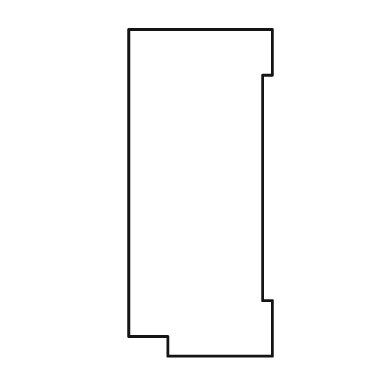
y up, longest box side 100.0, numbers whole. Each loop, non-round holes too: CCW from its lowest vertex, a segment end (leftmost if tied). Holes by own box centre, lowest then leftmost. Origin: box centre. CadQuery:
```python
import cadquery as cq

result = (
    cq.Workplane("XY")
    .moveTo(-10.0, -50.0)
    .lineTo(22.0, -50.0)
    .lineTo(22.0, -33.0)
    .lineTo(19.0, -33.0)
    .lineTo(19.0, 36.0)
    .lineTo(22.0, 36.0)
    .lineTo(22.0, 50.0)
    .lineTo(-22.0, 50.0)
    .lineTo(-22.0, -44.0)
    .lineTo(-10.0, -44.0)
    .close()
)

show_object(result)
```